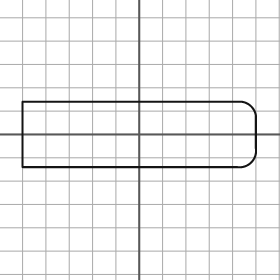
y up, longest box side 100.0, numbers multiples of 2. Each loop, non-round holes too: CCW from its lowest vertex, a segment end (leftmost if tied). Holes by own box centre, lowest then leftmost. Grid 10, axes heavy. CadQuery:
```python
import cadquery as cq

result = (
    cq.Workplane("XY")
    .moveTo(-50.0, -14.0)
    .lineTo(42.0, -14.0)
    .threePointArc((48.0, -12.0), (50.0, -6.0))
    .lineTo(50.0, 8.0)
    .threePointArc((48.0, 12.0), (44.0, 14.0))
    .lineTo(-50.0, 14.0)
    .close()
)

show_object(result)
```